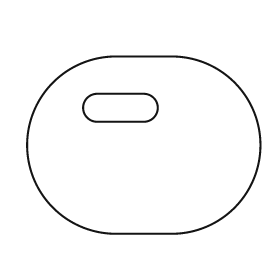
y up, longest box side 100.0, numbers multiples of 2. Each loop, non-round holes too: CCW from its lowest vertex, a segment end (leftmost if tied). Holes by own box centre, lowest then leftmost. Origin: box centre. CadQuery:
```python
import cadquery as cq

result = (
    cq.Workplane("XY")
    .moveTo(-12.0, -38.0)
    .lineTo(12.0, -38.0)
    .threePointArc((50.0, 0.0), (12.0, 38.0))
    .lineTo(-12.0, 38.0)
    .threePointArc((-50.0, 0.0), (-12.0, -38.0))
    .close()
    .moveTo(-20.0, 10.0)
    .lineTo(0.0, 10.0)
    .threePointArc((6.0, 16.0), (0.0, 22.0))
    .lineTo(-20.0, 22.0)
    .threePointArc((-26.0, 16.0), (-20.0, 10.0))
    .close()
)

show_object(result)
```